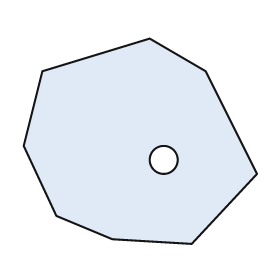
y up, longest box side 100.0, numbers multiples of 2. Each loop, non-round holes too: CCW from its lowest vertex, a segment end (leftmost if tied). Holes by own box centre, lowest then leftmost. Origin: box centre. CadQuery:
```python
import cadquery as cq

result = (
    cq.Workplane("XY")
    .moveTo(22.0, -44.0)
    .lineTo(50.0, -14.0)
    .lineTo(28.0, 30.0)
    .lineTo(4.0, 44.0)
    .lineTo(-42.0, 30.0)
    .lineTo(-50.0, -2.0)
    .lineTo(-36.0, -32.0)
    .lineTo(-12.0, -42.0)
    .close()
    .moveTo(10.0, -8.0)
    .circle(6.0)
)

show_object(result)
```